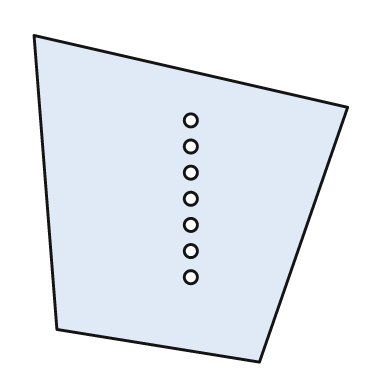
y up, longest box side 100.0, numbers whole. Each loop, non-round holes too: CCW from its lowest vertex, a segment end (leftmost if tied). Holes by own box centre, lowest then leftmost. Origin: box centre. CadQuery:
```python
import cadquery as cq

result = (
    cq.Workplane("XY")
    .moveTo(21.0, -50.0)
    .lineTo(48.0, 28.0)
    .lineTo(-48.0, 50.0)
    .lineTo(-41.0, -40.0)
    .close()
    .moveTo(0.0, -24.0)
    .circle(2.0)
    .moveTo(0.0, -16.0)
    .circle(2.0)
    .moveTo(0.0, -8.0)
    .circle(2.0)
    .moveTo(0.0, 0.0)
    .circle(2.0)
    .moveTo(0.0, 8.0)
    .circle(2.0)
    .moveTo(0.0, 16.0)
    .circle(2.0)
    .moveTo(0.0, 24.0)
    .circle(2.0)
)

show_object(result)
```